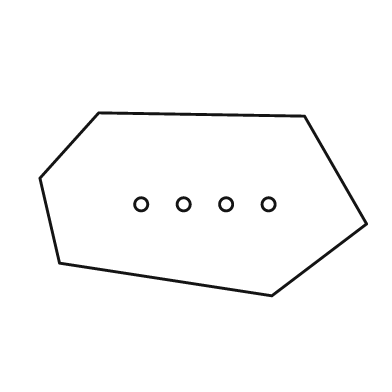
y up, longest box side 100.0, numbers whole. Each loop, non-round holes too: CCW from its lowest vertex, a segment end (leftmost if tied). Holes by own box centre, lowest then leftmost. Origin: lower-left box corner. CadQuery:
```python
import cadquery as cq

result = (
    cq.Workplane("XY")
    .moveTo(71.0, 0.0)
    .lineTo(100.0, 22.0)
    .lineTo(81.0, 55.0)
    .lineTo(18.0, 56.0)
    .lineTo(0.0, 36.0)
    .lineTo(6.0, 10.0)
    .close()
    .moveTo(31.0, 28.0)
    .circle(2.0)
    .moveTo(44.0, 28.0)
    .circle(2.0)
    .moveTo(57.0, 28.0)
    .circle(2.0)
    .moveTo(70.0, 28.0)
    .circle(2.0)
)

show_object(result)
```